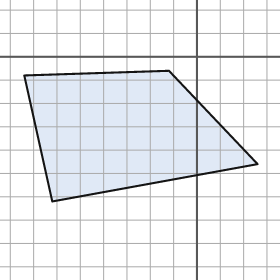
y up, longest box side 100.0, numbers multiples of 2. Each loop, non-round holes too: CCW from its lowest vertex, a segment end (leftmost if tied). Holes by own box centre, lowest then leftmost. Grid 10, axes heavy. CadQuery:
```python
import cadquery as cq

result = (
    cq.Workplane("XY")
    .moveTo(-62.0, -62.0)
    .lineTo(26.0, -46.0)
    .lineTo(-12.0, -6.0)
    .lineTo(-74.0, -8.0)
    .close()
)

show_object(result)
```